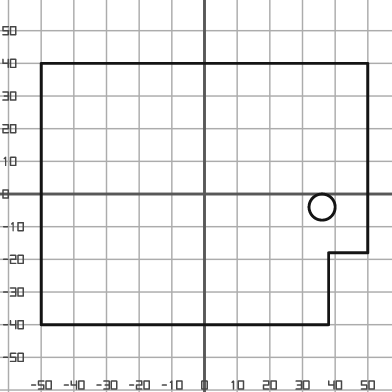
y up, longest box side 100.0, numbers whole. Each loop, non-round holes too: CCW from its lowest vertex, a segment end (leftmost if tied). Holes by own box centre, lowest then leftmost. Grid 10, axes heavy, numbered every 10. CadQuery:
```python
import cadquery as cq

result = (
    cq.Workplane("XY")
    .moveTo(-50.0, -40.0)
    .lineTo(38.0, -40.0)
    .lineTo(38.0, -18.0)
    .lineTo(50.0, -18.0)
    .lineTo(50.0, 40.0)
    .lineTo(-50.0, 40.0)
    .close()
    .moveTo(36.0, -4.0)
    .circle(4.0)
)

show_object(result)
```